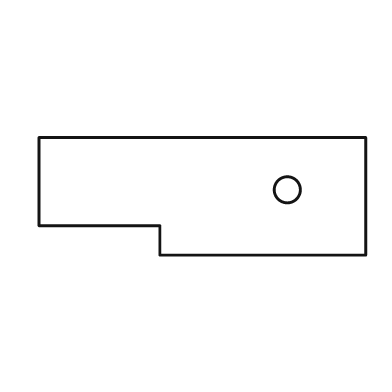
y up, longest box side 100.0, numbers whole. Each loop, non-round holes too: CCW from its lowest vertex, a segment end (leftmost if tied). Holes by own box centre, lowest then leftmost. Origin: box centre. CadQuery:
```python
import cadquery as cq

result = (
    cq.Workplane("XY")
    .moveTo(-13.0, -18.0)
    .lineTo(50.0, -18.0)
    .lineTo(50.0, 18.0)
    .lineTo(-50.0, 18.0)
    .lineTo(-50.0, -9.0)
    .lineTo(-13.0, -9.0)
    .close()
    .moveTo(26.0, 2.0)
    .circle(4.0)
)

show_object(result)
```